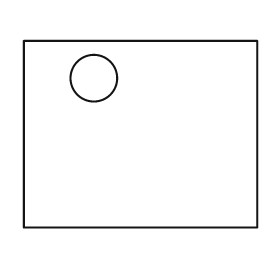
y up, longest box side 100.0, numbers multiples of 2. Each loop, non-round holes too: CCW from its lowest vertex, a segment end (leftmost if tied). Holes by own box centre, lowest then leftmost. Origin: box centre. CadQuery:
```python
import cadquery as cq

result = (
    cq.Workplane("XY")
    .moveTo(-50.0, -40.0)
    .lineTo(50.0, -40.0)
    .lineTo(50.0, 40.0)
    .lineTo(-50.0, 40.0)
    .close()
    .moveTo(-20.0, 24.0)
    .circle(10.0)
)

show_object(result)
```